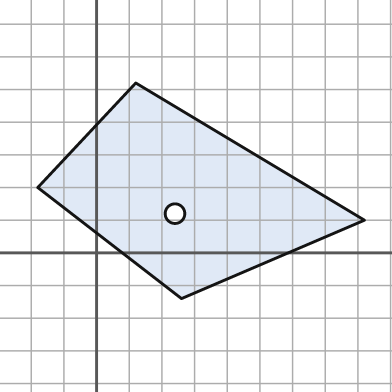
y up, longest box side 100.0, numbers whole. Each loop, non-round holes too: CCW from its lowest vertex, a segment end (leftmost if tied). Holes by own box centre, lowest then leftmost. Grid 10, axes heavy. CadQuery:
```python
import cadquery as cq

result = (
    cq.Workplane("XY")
    .moveTo(26.0, -14.0)
    .lineTo(82.0, 10.0)
    .lineTo(12.0, 52.0)
    .lineTo(-18.0, 20.0)
    .close()
    .moveTo(24.0, 12.0)
    .circle(3.0)
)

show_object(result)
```